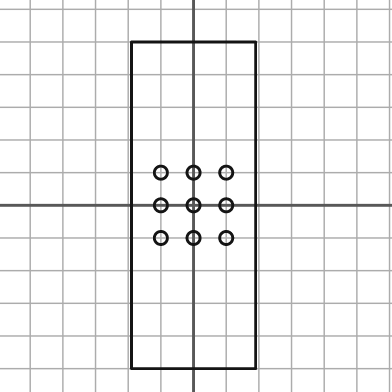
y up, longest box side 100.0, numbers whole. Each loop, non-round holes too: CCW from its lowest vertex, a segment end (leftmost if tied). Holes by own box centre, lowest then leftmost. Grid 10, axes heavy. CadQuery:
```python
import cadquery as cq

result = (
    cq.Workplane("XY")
    .moveTo(-19.0, -50.0)
    .lineTo(19.0, -50.0)
    .lineTo(19.0, 50.0)
    .lineTo(-19.0, 50.0)
    .close()
    .moveTo(-10.0, -10.0)
    .circle(2.0)
    .moveTo(0.0, -10.0)
    .circle(2.0)
    .moveTo(10.0, -10.0)
    .circle(2.0)
    .moveTo(-10.0, 0.0)
    .circle(2.0)
    .moveTo(0.0, 0.0)
    .circle(2.0)
    .moveTo(10.0, 0.0)
    .circle(2.0)
    .moveTo(-10.0, 10.0)
    .circle(2.0)
    .moveTo(0.0, 10.0)
    .circle(2.0)
    .moveTo(10.0, 10.0)
    .circle(2.0)
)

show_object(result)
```